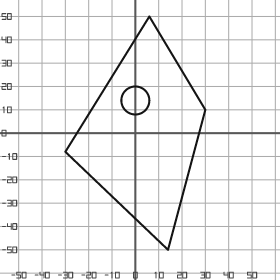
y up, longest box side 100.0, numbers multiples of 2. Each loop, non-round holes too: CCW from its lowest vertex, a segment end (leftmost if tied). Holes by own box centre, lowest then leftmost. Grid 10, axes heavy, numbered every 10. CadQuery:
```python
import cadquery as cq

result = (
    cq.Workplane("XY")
    .moveTo(14.0, -50.0)
    .lineTo(30.0, 10.0)
    .lineTo(6.0, 50.0)
    .lineTo(-30.0, -8.0)
    .close()
    .moveTo(0.0, 14.0)
    .circle(6.0)
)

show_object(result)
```